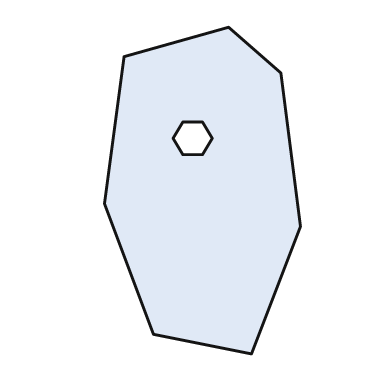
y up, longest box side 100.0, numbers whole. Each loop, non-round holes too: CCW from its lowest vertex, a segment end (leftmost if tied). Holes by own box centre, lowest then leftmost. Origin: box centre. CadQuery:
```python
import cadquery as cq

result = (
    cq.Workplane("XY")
    .moveTo(15.0, -50.0)
    .lineTo(30.0, -11.0)
    .lineTo(24.0, 36.0)
    .lineTo(8.0, 50.0)
    .lineTo(-24.0, 41.0)
    .lineTo(-30.0, -4.0)
    .lineTo(-15.0, -44.0)
    .close()
    .moveTo(-6.0, 11.0)
    .lineTo(0.0, 11.0)
    .lineTo(3.0, 16.0)
    .lineTo(0.0, 21.0)
    .lineTo(-6.0, 21.0)
    .lineTo(-9.0, 16.0)
    .close()
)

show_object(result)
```